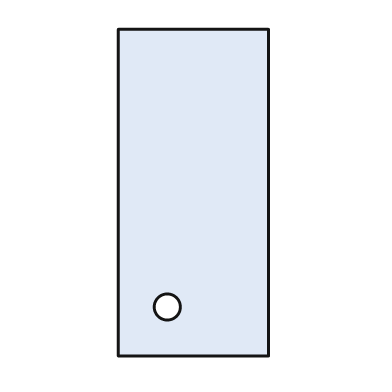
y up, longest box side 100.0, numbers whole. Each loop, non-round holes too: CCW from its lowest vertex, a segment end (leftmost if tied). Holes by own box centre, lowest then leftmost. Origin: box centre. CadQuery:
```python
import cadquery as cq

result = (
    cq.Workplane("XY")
    .moveTo(-23.0, -50.0)
    .lineTo(23.0, -50.0)
    .lineTo(23.0, 50.0)
    .lineTo(-23.0, 50.0)
    .close()
    .moveTo(-8.0, -35.0)
    .circle(4.0)
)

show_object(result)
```